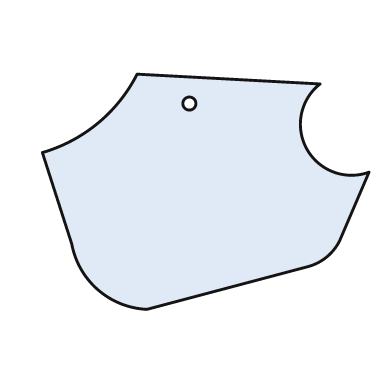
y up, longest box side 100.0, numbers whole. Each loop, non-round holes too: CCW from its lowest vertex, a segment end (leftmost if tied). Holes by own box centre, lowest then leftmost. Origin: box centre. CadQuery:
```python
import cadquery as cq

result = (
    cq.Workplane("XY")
    .moveTo(-18.0, -36.0)
    .lineTo(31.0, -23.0)
    .threePointArc((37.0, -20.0), (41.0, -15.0))
    .lineTo(50.0, 6.0)
    .threePointArc((31.0, 13.0), (35.0, 33.0))
    .lineTo(-21.0, 36.0)
    .threePointArc((-33.0, 21.0), (-50.0, 12.0))
    .lineTo(-41.0, -16.0)
    .threePointArc((-33.0, -30.0), (-18.0, -36.0))
    .close()
    .moveTo(-5.0, 27.0)
    .circle(2.0)
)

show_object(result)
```